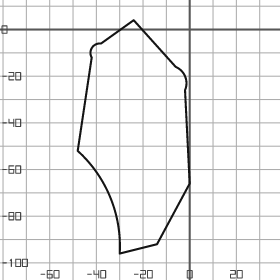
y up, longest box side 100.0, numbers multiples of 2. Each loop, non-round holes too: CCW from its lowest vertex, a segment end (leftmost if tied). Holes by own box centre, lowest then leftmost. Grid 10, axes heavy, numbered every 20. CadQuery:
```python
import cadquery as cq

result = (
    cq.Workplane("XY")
    .moveTo(-30.0, -96.0)
    .lineTo(-14.0, -92.0)
    .lineTo(0.0, -66.0)
    .lineTo(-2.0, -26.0)
    .threePointArc((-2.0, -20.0), (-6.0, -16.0))
    .lineTo(-24.0, 4.0)
    .lineTo(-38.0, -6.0)
    .threePointArc((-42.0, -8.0), (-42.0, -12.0))
    .lineTo(-48.0, -52.0)
    .threePointArc((-34.0, -72.0), (-30.0, -96.0))
    .close()
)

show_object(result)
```